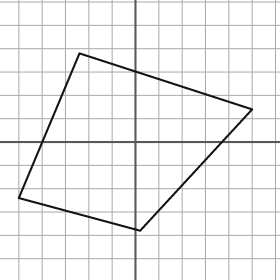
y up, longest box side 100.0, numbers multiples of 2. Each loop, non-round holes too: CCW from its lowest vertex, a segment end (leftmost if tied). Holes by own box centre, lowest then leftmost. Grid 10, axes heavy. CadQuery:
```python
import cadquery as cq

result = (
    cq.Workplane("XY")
    .moveTo(2.0, -38.0)
    .lineTo(50.0, 14.0)
    .lineTo(-24.0, 38.0)
    .lineTo(-50.0, -24.0)
    .close()
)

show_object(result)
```